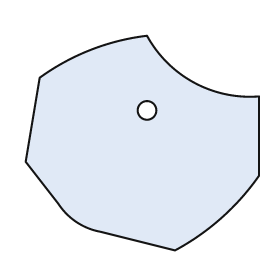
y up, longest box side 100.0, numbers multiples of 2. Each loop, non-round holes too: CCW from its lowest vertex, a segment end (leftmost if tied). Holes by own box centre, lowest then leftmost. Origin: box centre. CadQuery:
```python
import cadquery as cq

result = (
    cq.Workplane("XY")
    .moveTo(14.0, -46.0)
    .threePointArc((34.0, -32.0), (50.0, -14.0))
    .lineTo(50.0, 20.0)
    .threePointArc((22.0, 26.0), (2.0, 46.0))
    .threePointArc((-22.0, 40.0), (-44.0, 28.0))
    .lineTo(-50.0, -8.0)
    .lineTo(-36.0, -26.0)
    .threePointArc((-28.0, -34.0), (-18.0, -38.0))
    .close()
    .moveTo(2.0, 14.0)
    .circle(4.0)
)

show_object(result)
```